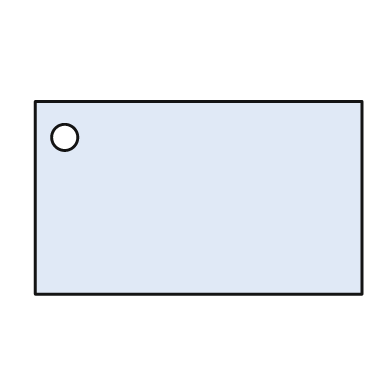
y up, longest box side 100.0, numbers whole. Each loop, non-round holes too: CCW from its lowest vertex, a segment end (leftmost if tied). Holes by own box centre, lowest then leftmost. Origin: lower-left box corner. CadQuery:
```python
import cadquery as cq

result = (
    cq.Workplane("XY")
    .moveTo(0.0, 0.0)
    .lineTo(100.0, 0.0)
    .lineTo(100.0, 59.0)
    .lineTo(0.0, 59.0)
    .close()
    .moveTo(9.0, 48.0)
    .circle(4.0)
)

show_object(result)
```